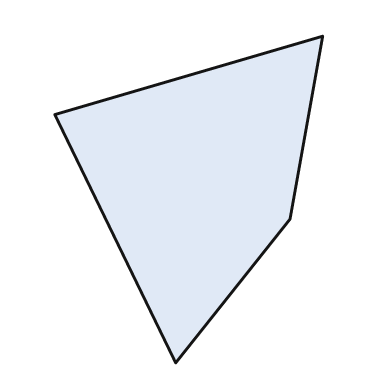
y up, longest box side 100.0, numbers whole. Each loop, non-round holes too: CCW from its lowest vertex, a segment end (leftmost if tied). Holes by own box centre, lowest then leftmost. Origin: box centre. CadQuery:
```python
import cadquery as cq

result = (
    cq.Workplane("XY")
    .moveTo(-4.0, -50.0)
    .lineTo(31.0, -6.0)
    .lineTo(41.0, 50.0)
    .lineTo(-41.0, 26.0)
    .close()
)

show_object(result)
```